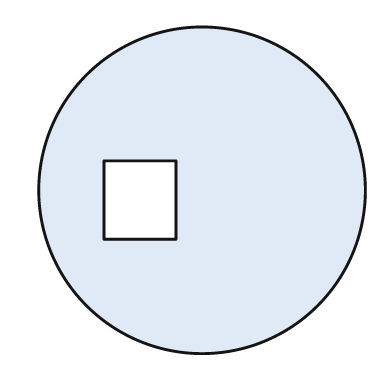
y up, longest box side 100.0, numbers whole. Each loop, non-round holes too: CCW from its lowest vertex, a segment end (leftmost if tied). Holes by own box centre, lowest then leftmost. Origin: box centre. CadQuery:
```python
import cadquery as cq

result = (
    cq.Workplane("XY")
    .moveTo(0.0, 0.0)
    .circle(50.0)
    .moveTo(-30.0, -15.0)
    .lineTo(-8.0, -15.0)
    .lineTo(-8.0, 9.0)
    .lineTo(-30.0, 9.0)
    .close()
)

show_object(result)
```